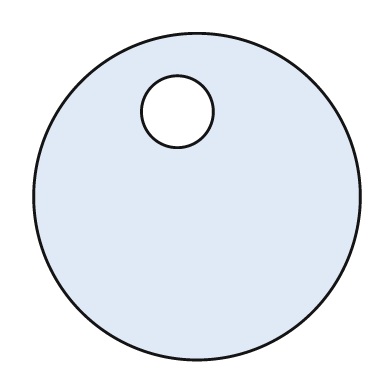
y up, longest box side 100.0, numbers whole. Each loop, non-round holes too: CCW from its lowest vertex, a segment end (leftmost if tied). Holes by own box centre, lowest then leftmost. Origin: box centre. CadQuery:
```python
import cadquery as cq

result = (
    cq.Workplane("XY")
    .moveTo(0.0, 0.0)
    .circle(50.0)
    .moveTo(-6.0, 26.0)
    .circle(11.0)
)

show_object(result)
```